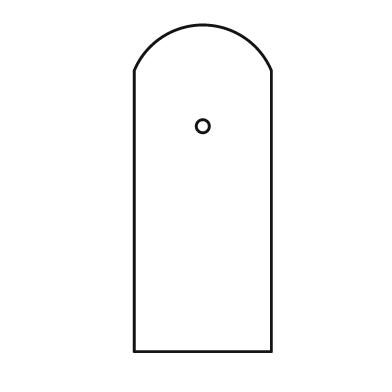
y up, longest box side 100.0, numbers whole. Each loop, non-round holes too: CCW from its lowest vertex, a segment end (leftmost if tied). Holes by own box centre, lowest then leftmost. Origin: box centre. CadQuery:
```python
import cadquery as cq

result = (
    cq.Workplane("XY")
    .moveTo(-21.0, -50.0)
    .lineTo(21.0, -50.0)
    .lineTo(21.0, 36.0)
    .threePointArc((0.0, 50.0), (-21.0, 36.0))
    .close()
    .moveTo(0.0, 19.0)
    .circle(2.0)
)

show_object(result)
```